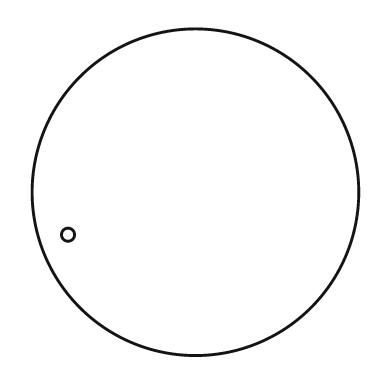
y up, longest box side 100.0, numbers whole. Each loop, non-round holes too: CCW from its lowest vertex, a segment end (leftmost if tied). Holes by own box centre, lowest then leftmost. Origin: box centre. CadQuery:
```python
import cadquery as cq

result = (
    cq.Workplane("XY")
    .moveTo(0.0, 0.0)
    .circle(50.0)
    .moveTo(-39.0, -13.0)
    .circle(2.0)
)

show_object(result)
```